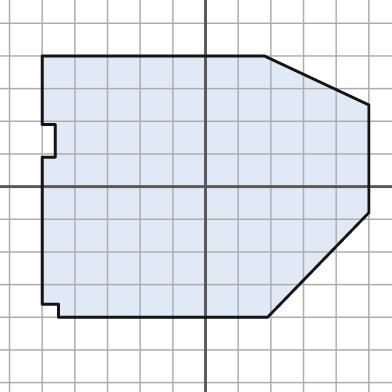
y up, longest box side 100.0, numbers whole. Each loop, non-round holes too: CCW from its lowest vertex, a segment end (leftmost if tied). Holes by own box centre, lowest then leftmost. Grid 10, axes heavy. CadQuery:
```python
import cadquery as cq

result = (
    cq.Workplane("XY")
    .moveTo(-45.0, -40.0)
    .lineTo(19.0, -40.0)
    .lineTo(50.0, -8.0)
    .lineTo(50.0, 25.0)
    .lineTo(18.0, 40.0)
    .lineTo(-50.0, 40.0)
    .lineTo(-50.0, 19.0)
    .lineTo(-46.0, 19.0)
    .lineTo(-46.0, 9.0)
    .lineTo(-50.0, 9.0)
    .lineTo(-50.0, -36.0)
    .lineTo(-45.0, -36.0)
    .close()
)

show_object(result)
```